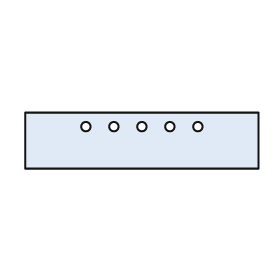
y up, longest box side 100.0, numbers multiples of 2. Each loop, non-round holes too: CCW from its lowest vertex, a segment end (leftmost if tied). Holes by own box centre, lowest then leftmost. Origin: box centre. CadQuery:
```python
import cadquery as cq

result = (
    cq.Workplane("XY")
    .moveTo(-50.0, -12.0)
    .lineTo(50.0, -12.0)
    .lineTo(50.0, 12.0)
    .lineTo(-50.0, 12.0)
    .close()
    .moveTo(-24.0, 6.0)
    .circle(2.0)
    .moveTo(-12.0, 6.0)
    .circle(2.0)
    .moveTo(0.0, 6.0)
    .circle(2.0)
    .moveTo(12.0, 6.0)
    .circle(2.0)
    .moveTo(24.0, 6.0)
    .circle(2.0)
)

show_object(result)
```